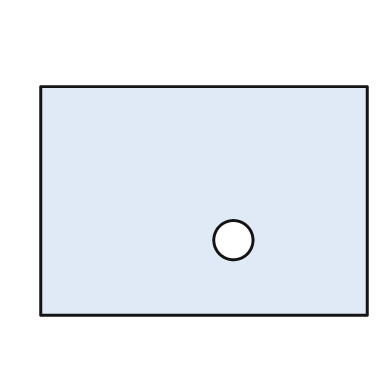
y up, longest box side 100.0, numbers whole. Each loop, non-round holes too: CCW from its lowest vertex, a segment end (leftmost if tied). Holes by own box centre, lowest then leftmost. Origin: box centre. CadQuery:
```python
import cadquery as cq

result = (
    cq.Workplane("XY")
    .moveTo(-50.0, -35.0)
    .lineTo(50.0, -35.0)
    .lineTo(50.0, 35.0)
    .lineTo(-50.0, 35.0)
    .close()
    .moveTo(9.0, -12.0)
    .circle(6.0)
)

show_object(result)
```